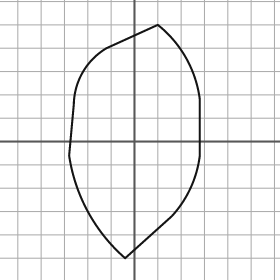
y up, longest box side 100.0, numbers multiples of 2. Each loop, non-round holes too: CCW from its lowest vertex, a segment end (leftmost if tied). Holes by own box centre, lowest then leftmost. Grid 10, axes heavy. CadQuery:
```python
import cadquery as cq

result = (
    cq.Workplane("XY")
    .moveTo(-4.0, -50.0)
    .lineTo(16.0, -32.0)
    .threePointArc((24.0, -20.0), (28.0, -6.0))
    .lineTo(28.0, 18.0)
    .threePointArc((22.0, 36.0), (10.0, 50.0))
    .lineTo(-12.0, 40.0)
    .threePointArc((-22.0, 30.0), (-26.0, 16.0))
    .lineTo(-28.0, -6.0)
    .threePointArc((-20.0, -30.0), (-4.0, -50.0))
    .close()
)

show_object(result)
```